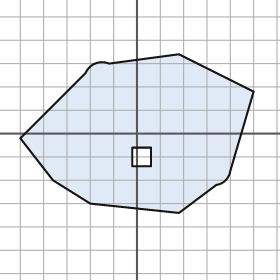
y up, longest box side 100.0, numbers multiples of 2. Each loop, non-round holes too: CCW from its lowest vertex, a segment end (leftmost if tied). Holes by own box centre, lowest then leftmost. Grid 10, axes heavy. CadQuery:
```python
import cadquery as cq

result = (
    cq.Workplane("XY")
    .moveTo(18.0, -34.0)
    .lineTo(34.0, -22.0)
    .threePointArc((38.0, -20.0), (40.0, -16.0))
    .lineTo(50.0, 18.0)
    .lineTo(18.0, 34.0)
    .lineTo(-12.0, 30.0)
    .threePointArc((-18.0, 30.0), (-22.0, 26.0))
    .lineTo(-50.0, -2.0)
    .lineTo(-36.0, -20.0)
    .lineTo(-20.0, -30.0)
    .close()
    .moveTo(-2.0, -14.0)
    .lineTo(6.0, -14.0)
    .lineTo(6.0, -6.0)
    .lineTo(-2.0, -6.0)
    .close()
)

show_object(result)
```